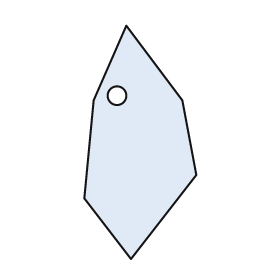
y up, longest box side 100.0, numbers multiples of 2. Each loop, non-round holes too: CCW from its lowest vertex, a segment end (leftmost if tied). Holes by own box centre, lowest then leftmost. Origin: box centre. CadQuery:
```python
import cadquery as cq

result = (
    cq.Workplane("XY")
    .moveTo(-4.0, -50.0)
    .lineTo(24.0, -14.0)
    .lineTo(18.0, 18.0)
    .lineTo(-6.0, 50.0)
    .lineTo(-20.0, 18.0)
    .lineTo(-24.0, -24.0)
    .close()
    .moveTo(-10.0, 20.0)
    .circle(4.0)
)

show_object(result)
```